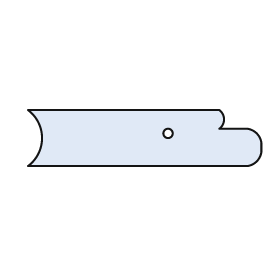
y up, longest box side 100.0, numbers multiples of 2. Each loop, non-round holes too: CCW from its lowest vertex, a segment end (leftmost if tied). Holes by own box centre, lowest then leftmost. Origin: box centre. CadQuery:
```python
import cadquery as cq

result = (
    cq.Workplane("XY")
    .moveTo(-50.0, -12.0)
    .lineTo(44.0, -12.0)
    .threePointArc((48.0, -10.0), (50.0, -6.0))
    .lineTo(50.0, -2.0)
    .threePointArc((48.0, 2.0), (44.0, 4.0))
    .lineTo(32.0, 4.0)
    .threePointArc((34.0, 8.0), (32.0, 12.0))
    .lineTo(-50.0, 12.0)
    .threePointArc((-44.0, 0.0), (-50.0, -12.0))
    .close()
    .moveTo(10.0, 2.0)
    .circle(2.0)
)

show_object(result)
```